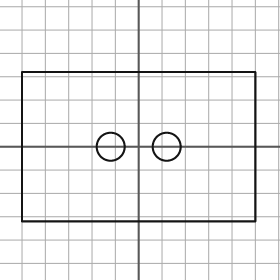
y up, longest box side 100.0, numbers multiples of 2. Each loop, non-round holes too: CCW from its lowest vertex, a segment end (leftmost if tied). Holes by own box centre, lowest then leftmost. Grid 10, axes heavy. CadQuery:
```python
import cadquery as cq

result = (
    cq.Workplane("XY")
    .moveTo(-50.0, -32.0)
    .lineTo(50.0, -32.0)
    .lineTo(50.0, 32.0)
    .lineTo(-50.0, 32.0)
    .close()
    .moveTo(-12.0, 0.0)
    .circle(6.0)
    .moveTo(12.0, 0.0)
    .circle(6.0)
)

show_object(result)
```